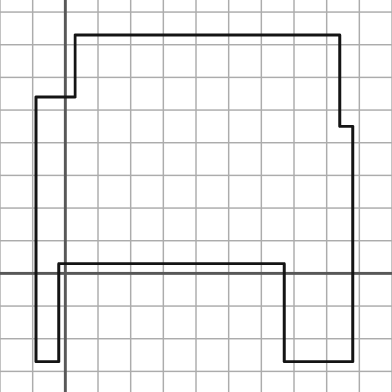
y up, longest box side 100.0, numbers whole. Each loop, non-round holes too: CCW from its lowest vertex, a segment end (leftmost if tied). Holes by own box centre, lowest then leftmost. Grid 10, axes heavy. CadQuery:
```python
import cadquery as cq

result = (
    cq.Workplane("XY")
    .moveTo(-9.0, -27.0)
    .lineTo(-2.0, -27.0)
    .lineTo(-2.0, 3.0)
    .lineTo(67.0, 3.0)
    .lineTo(67.0, -27.0)
    .lineTo(88.0, -27.0)
    .lineTo(88.0, 45.0)
    .lineTo(84.0, 45.0)
    .lineTo(84.0, 73.0)
    .lineTo(3.0, 73.0)
    .lineTo(3.0, 54.0)
    .lineTo(-9.0, 54.0)
    .close()
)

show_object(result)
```